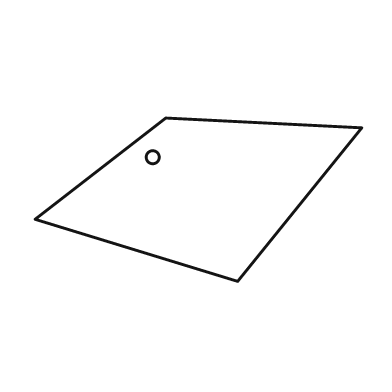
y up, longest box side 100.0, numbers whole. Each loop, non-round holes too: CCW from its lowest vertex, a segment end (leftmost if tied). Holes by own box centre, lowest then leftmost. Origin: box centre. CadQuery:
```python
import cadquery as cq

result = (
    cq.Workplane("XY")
    .moveTo(12.0, -25.0)
    .lineTo(50.0, 22.0)
    .lineTo(-10.0, 25.0)
    .lineTo(-50.0, -6.0)
    .close()
    .moveTo(-14.0, 13.0)
    .circle(2.0)
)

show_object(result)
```